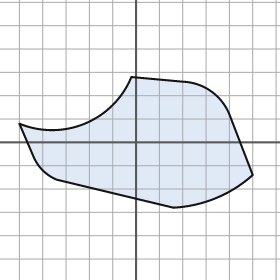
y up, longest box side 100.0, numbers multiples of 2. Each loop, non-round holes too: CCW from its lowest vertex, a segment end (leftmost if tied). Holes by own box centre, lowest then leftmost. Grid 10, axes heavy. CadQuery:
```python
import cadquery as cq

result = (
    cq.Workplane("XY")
    .moveTo(16.0, -28.0)
    .threePointArc((34.0, -24.0), (50.0, -14.0))
    .lineTo(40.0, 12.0)
    .threePointArc((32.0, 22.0), (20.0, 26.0))
    .lineTo(-2.0, 28.0)
    .threePointArc((-22.0, 8.0), (-50.0, 8.0))
    .lineTo(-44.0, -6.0)
    .threePointArc((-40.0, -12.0), (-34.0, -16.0))
    .close()
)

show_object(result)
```